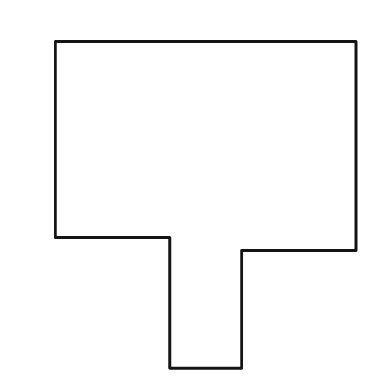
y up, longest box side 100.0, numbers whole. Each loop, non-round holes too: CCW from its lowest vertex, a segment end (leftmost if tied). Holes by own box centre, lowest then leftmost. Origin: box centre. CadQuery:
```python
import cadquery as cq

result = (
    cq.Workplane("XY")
    .moveTo(-11.0, -50.0)
    .lineTo(11.0, -50.0)
    .lineTo(11.0, -14.0)
    .lineTo(46.0, -14.0)
    .lineTo(46.0, 50.0)
    .lineTo(-46.0, 50.0)
    .lineTo(-46.0, -10.0)
    .lineTo(-11.0, -10.0)
    .close()
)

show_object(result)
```